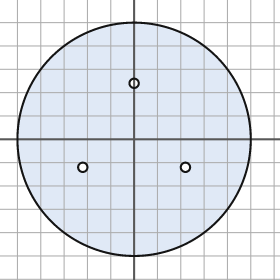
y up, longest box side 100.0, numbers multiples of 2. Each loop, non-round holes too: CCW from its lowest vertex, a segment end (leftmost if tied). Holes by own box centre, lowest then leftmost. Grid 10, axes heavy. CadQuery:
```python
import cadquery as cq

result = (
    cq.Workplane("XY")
    .moveTo(0.0, 0.0)
    .circle(50.0)
    .moveTo(-22.0, -12.0)
    .circle(2.0)
    .moveTo(22.0, -12.0)
    .circle(2.0)
    .moveTo(0.0, 24.0)
    .circle(2.0)
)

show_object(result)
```